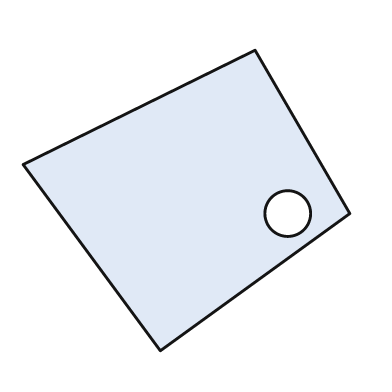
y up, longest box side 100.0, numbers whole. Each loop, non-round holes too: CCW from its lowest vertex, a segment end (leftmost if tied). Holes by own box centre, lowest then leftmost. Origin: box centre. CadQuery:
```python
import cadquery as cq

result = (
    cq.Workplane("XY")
    .moveTo(-8.0, -46.0)
    .lineTo(50.0, -4.0)
    .lineTo(21.0, 46.0)
    .lineTo(-50.0, 11.0)
    .close()
    .moveTo(31.0, -4.0)
    .circle(7.0)
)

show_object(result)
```